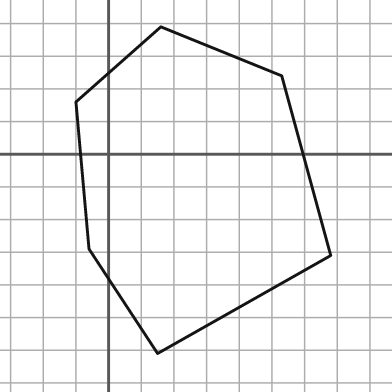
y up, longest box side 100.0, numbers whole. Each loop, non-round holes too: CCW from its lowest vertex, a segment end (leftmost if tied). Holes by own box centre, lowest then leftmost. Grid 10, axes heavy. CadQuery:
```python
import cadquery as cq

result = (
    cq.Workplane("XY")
    .moveTo(15.0, -61.0)
    .lineTo(68.0, -31.0)
    .lineTo(53.0, 24.0)
    .lineTo(16.0, 39.0)
    .lineTo(-10.0, 16.0)
    .lineTo(-6.0, -29.0)
    .close()
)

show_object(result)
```